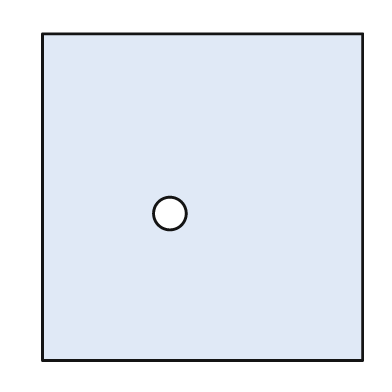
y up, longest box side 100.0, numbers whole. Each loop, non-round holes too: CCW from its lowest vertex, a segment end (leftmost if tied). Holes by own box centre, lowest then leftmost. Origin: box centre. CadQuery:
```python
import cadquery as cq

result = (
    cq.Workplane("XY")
    .moveTo(-49.0, -50.0)
    .lineTo(49.0, -50.0)
    .lineTo(49.0, 50.0)
    .lineTo(-49.0, 50.0)
    .close()
    .moveTo(-10.0, -5.0)
    .circle(5.0)
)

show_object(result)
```